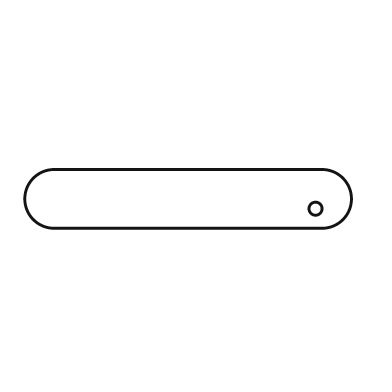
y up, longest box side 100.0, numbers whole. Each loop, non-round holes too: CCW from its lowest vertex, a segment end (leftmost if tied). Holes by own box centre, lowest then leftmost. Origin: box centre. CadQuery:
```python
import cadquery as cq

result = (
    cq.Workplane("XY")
    .moveTo(-41.0, -9.0)
    .lineTo(41.0, -9.0)
    .threePointArc((50.0, 0.0), (41.0, 9.0))
    .lineTo(-41.0, 9.0)
    .threePointArc((-50.0, 0.0), (-41.0, -9.0))
    .close()
    .moveTo(39.0, -3.0)
    .circle(2.0)
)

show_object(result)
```